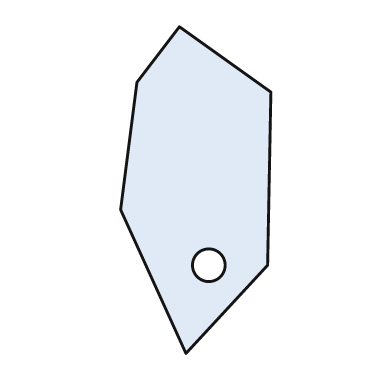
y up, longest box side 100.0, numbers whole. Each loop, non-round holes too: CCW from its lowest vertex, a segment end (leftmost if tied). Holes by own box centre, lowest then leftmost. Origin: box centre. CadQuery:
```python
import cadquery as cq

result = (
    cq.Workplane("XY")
    .moveTo(-3.0, -50.0)
    .lineTo(22.0, -23.0)
    .lineTo(23.0, 30.0)
    .lineTo(-5.0, 50.0)
    .lineTo(-18.0, 33.0)
    .lineTo(-23.0, -6.0)
    .close()
    .moveTo(4.0, -23.0)
    .circle(5.0)
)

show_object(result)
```